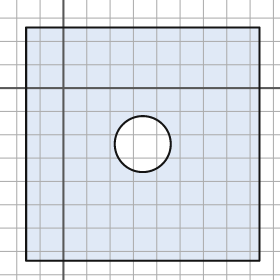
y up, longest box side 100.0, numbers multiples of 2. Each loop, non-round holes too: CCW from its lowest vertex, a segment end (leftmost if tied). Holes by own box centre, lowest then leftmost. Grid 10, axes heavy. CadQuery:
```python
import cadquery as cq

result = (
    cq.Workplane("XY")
    .moveTo(-16.0, -74.0)
    .lineTo(84.0, -74.0)
    .lineTo(84.0, 26.0)
    .lineTo(-16.0, 26.0)
    .close()
    .moveTo(34.0, -24.0)
    .circle(12.0)
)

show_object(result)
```